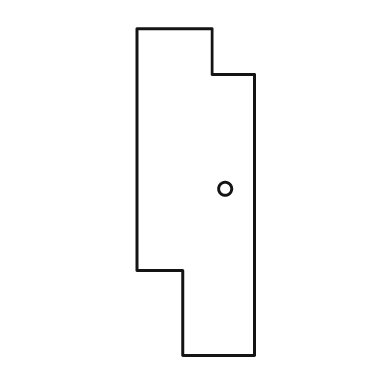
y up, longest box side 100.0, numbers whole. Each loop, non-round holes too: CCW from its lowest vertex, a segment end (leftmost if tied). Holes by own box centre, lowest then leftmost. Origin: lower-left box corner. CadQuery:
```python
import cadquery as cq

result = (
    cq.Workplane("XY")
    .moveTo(14.0, 0.0)
    .lineTo(36.0, 0.0)
    .lineTo(36.0, 86.0)
    .lineTo(23.0, 86.0)
    .lineTo(23.0, 100.0)
    .lineTo(0.0, 100.0)
    .lineTo(0.0, 26.0)
    .lineTo(14.0, 26.0)
    .close()
    .moveTo(27.0, 51.0)
    .circle(2.0)
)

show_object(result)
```